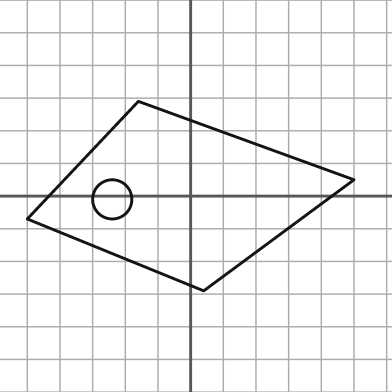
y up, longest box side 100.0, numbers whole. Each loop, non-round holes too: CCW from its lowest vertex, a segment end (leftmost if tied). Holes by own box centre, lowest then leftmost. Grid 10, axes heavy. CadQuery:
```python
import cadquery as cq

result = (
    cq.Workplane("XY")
    .moveTo(4.0, -29.0)
    .lineTo(50.0, 5.0)
    .lineTo(-16.0, 29.0)
    .lineTo(-50.0, -7.0)
    .close()
    .moveTo(-24.0, -1.0)
    .circle(6.0)
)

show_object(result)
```